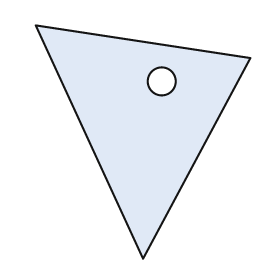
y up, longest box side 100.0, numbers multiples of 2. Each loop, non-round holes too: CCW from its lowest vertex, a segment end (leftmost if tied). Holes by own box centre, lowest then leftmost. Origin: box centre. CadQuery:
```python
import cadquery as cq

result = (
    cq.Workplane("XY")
    .moveTo(0.0, -50.0)
    .lineTo(46.0, 36.0)
    .lineTo(-46.0, 50.0)
    .close()
    .moveTo(8.0, 26.0)
    .circle(6.0)
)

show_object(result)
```